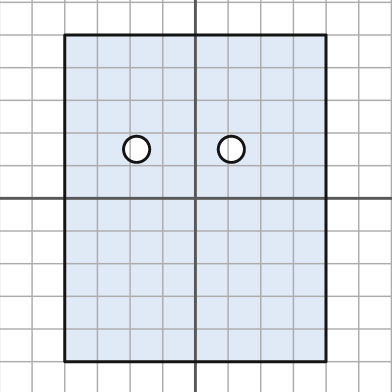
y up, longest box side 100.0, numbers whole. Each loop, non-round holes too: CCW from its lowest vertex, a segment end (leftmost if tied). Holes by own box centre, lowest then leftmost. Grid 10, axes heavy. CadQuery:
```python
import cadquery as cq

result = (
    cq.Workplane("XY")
    .moveTo(-40.0, -50.0)
    .lineTo(40.0, -50.0)
    .lineTo(40.0, 50.0)
    .lineTo(-40.0, 50.0)
    .close()
    .moveTo(-18.0, 15.0)
    .circle(4.0)
    .moveTo(11.0, 15.0)
    .circle(4.0)
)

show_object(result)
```